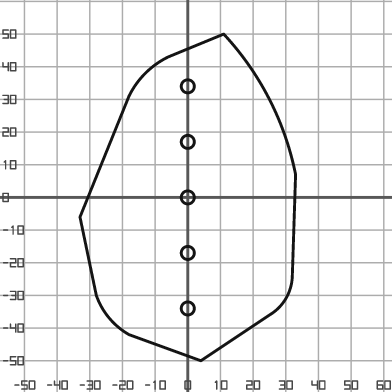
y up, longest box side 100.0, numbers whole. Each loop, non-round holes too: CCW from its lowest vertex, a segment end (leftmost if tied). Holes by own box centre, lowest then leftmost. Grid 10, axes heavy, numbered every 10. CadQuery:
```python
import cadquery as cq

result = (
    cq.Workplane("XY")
    .moveTo(4.0, -50.0)
    .lineTo(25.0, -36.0)
    .threePointArc((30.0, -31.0), (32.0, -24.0))
    .lineTo(33.0, 7.0)
    .threePointArc((25.0, 30.0), (11.0, 50.0))
    .lineTo(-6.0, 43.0)
    .threePointArc((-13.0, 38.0), (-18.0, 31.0))
    .lineTo(-33.0, -6.0)
    .lineTo(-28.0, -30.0)
    .threePointArc((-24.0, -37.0), (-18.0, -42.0))
    .close()
    .moveTo(0.0, -34.0)
    .circle(2.0)
    .moveTo(0.0, -17.0)
    .circle(2.0)
    .moveTo(0.0, 0.0)
    .circle(2.0)
    .moveTo(0.0, 17.0)
    .circle(2.0)
    .moveTo(0.0, 34.0)
    .circle(2.0)
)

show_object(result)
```